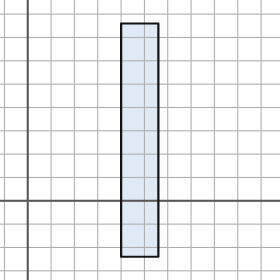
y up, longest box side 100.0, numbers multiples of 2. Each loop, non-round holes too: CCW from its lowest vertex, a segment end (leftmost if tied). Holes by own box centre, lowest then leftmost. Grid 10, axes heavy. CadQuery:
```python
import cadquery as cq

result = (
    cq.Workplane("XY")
    .moveTo(40.0, -24.0)
    .lineTo(56.0, -24.0)
    .lineTo(56.0, 76.0)
    .lineTo(40.0, 76.0)
    .close()
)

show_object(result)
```